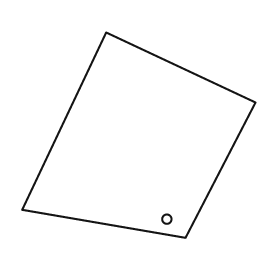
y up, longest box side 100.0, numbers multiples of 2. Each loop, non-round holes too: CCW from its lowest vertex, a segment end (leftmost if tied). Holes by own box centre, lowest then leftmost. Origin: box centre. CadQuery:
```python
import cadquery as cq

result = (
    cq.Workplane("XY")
    .moveTo(20.0, -44.0)
    .lineTo(50.0, 14.0)
    .lineTo(-14.0, 44.0)
    .lineTo(-50.0, -32.0)
    .close()
    .moveTo(12.0, -36.0)
    .circle(2.0)
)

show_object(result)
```